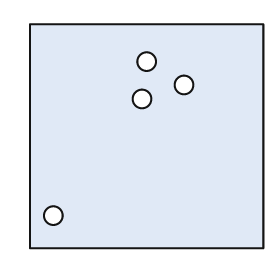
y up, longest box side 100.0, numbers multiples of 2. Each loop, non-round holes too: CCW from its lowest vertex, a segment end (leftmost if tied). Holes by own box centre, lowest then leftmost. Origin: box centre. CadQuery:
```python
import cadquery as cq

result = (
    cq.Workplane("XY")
    .moveTo(-50.0, -48.0)
    .lineTo(50.0, -48.0)
    .lineTo(50.0, 48.0)
    .lineTo(-50.0, 48.0)
    .close()
    .moveTo(-40.0, -34.0)
    .circle(4.0)
    .moveTo(-2.0, 16.0)
    .circle(4.0)
    .moveTo(16.0, 22.0)
    .circle(4.0)
    .moveTo(0.0, 32.0)
    .circle(4.0)
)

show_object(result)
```